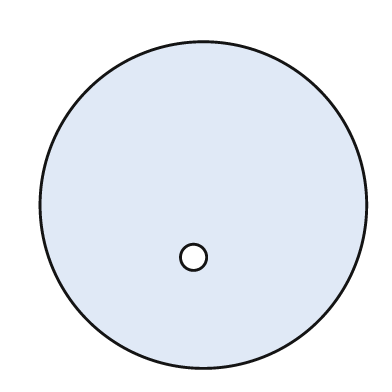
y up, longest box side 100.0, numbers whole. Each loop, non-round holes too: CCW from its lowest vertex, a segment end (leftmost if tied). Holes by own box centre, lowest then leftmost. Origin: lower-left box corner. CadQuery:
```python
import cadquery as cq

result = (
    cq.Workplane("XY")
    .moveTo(50.0, 50.0)
    .circle(50.0)
    .moveTo(47.0, 34.0)
    .circle(4.0)
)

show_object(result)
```